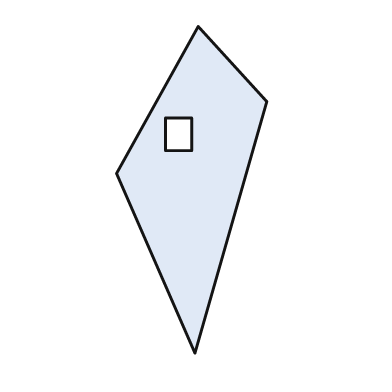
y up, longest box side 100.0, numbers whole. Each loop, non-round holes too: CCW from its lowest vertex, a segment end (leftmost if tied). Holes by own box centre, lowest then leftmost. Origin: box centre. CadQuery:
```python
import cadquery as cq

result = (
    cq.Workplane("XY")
    .moveTo(1.0, -50.0)
    .lineTo(23.0, 27.0)
    .lineTo(2.0, 50.0)
    .lineTo(-23.0, 5.0)
    .close()
    .moveTo(-8.0, 12.0)
    .lineTo(0.0, 12.0)
    .lineTo(0.0, 22.0)
    .lineTo(-8.0, 22.0)
    .close()
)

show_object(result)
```